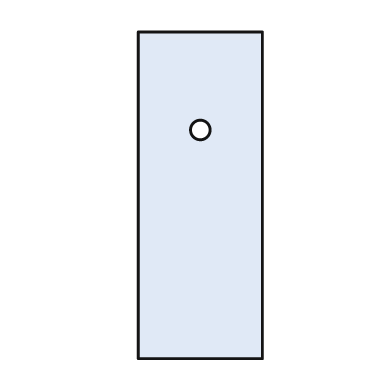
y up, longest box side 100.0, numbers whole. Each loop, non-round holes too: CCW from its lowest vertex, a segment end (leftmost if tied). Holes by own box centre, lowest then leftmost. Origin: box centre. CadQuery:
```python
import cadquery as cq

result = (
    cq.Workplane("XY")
    .moveTo(-19.0, -50.0)
    .lineTo(19.0, -50.0)
    .lineTo(19.0, 50.0)
    .lineTo(-19.0, 50.0)
    .close()
    .moveTo(0.0, 20.0)
    .circle(3.0)
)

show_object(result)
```